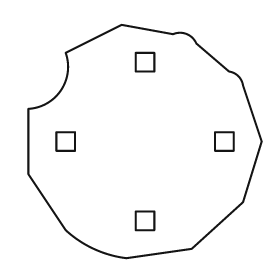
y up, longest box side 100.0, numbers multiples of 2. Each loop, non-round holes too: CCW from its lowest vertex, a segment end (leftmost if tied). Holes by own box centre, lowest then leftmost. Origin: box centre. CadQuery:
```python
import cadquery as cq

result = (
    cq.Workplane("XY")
    .moveTo(-8.0, -50.0)
    .lineTo(20.0, -46.0)
    .lineTo(42.0, -26.0)
    .lineTo(50.0, 0.0)
    .lineTo(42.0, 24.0)
    .threePointArc((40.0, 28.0), (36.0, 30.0))
    .lineTo(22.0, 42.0)
    .threePointArc((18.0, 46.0), (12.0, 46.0))
    .lineTo(-10.0, 50.0)
    .lineTo(-34.0, 38.0)
    .threePointArc((-36.0, 22.0), (-50.0, 14.0))
    .lineTo(-50.0, -14.0)
    .lineTo(-34.0, -38.0)
    .threePointArc((-22.0, -46.0), (-8.0, -50.0))
    .close()
    .moveTo(-4.0, -38.0)
    .lineTo(4.0, -38.0)
    .lineTo(4.0, -30.0)
    .lineTo(-4.0, -30.0)
    .close()
    .moveTo(-38.0, -4.0)
    .lineTo(-30.0, -4.0)
    .lineTo(-30.0, 4.0)
    .lineTo(-38.0, 4.0)
    .close()
    .moveTo(30.0, -4.0)
    .lineTo(38.0, -4.0)
    .lineTo(38.0, 4.0)
    .lineTo(30.0, 4.0)
    .close()
    .moveTo(-4.0, 30.0)
    .lineTo(4.0, 30.0)
    .lineTo(4.0, 38.0)
    .lineTo(-4.0, 38.0)
    .close()
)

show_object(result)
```